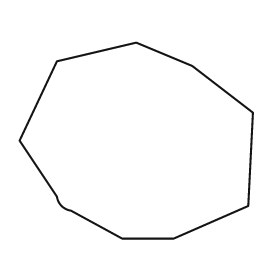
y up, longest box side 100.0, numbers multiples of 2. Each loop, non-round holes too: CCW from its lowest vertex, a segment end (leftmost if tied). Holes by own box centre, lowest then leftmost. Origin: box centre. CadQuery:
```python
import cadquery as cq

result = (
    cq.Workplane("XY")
    .moveTo(-6.0, -42.0)
    .lineTo(16.0, -42.0)
    .lineTo(48.0, -28.0)
    .lineTo(50.0, 12.0)
    .lineTo(24.0, 32.0)
    .lineTo(0.0, 42.0)
    .lineTo(-34.0, 34.0)
    .lineTo(-50.0, 0.0)
    .lineTo(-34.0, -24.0)
    .threePointArc((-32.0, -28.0), (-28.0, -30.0))
    .close()
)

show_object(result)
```